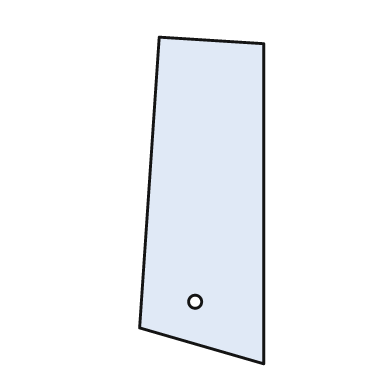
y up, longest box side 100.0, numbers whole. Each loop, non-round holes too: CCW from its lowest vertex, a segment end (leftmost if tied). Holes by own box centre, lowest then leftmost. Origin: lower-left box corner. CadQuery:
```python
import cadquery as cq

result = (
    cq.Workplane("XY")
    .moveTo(38.0, 0.0)
    .lineTo(38.0, 98.0)
    .lineTo(6.0, 100.0)
    .lineTo(0.0, 11.0)
    .close()
    .moveTo(17.0, 19.0)
    .circle(2.0)
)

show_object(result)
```